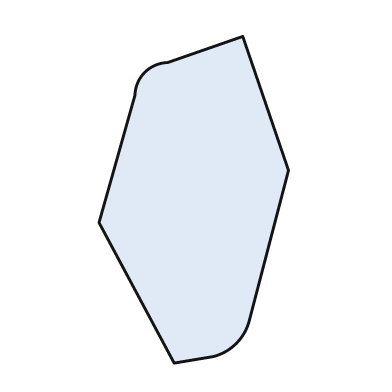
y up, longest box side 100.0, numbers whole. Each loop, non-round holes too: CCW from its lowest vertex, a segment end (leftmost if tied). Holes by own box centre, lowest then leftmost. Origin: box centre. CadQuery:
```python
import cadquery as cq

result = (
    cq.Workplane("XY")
    .moveTo(-6.0, -50.0)
    .lineTo(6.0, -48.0)
    .threePointArc((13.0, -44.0), (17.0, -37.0))
    .lineTo(29.0, 9.0)
    .lineTo(15.0, 50.0)
    .lineTo(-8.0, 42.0)
    .threePointArc((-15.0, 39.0), (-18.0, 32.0))
    .lineTo(-29.0, -7.0)
    .close()
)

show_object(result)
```